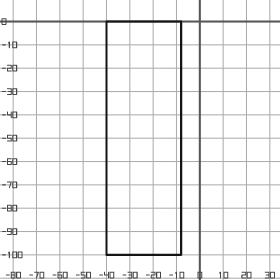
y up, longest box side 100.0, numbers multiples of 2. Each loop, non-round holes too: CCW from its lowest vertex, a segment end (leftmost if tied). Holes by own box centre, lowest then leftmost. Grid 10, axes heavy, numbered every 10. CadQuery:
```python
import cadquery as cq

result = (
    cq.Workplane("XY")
    .moveTo(-40.0, -100.0)
    .lineTo(-8.0, -100.0)
    .lineTo(-8.0, 0.0)
    .lineTo(-40.0, 0.0)
    .close()
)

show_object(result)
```